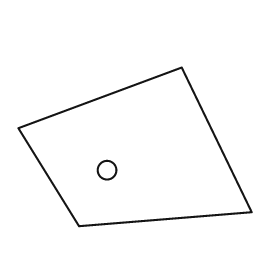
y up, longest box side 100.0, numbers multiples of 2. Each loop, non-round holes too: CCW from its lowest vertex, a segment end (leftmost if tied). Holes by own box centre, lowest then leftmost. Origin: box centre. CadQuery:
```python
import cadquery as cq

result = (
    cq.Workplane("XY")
    .moveTo(-24.0, -34.0)
    .lineTo(50.0, -28.0)
    .lineTo(20.0, 34.0)
    .lineTo(-50.0, 8.0)
    .close()
    .moveTo(-12.0, -10.0)
    .circle(4.0)
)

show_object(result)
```